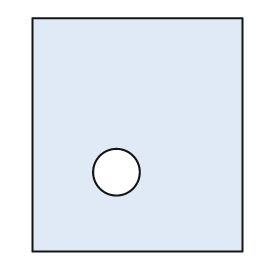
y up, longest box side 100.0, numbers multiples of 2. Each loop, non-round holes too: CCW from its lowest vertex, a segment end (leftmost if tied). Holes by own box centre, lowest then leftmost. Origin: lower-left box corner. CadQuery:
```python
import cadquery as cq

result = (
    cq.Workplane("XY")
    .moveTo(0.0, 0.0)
    .lineTo(90.0, 0.0)
    .lineTo(90.0, 100.0)
    .lineTo(0.0, 100.0)
    .close()
    .moveTo(36.0, 34.0)
    .circle(10.0)
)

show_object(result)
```